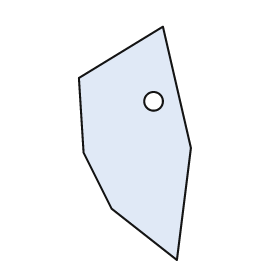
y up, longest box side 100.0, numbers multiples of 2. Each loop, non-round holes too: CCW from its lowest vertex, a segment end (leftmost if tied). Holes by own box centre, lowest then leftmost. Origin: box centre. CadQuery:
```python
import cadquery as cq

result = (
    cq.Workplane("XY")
    .moveTo(18.0, -50.0)
    .lineTo(24.0, -2.0)
    .lineTo(12.0, 50.0)
    .lineTo(-24.0, 28.0)
    .lineTo(-22.0, -4.0)
    .lineTo(-10.0, -28.0)
    .close()
    .moveTo(8.0, 18.0)
    .circle(4.0)
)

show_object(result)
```